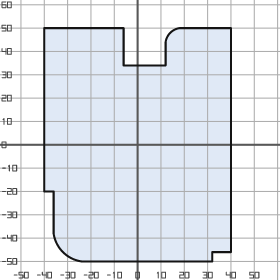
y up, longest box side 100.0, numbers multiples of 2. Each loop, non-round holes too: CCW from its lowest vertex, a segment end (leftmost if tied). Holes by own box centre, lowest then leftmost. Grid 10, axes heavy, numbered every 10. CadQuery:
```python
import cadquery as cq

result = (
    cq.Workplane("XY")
    .moveTo(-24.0, -50.0)
    .lineTo(32.0, -50.0)
    .lineTo(32.0, -46.0)
    .lineTo(40.0, -46.0)
    .lineTo(40.0, 50.0)
    .lineTo(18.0, 50.0)
    .threePointArc((14.0, 48.0), (12.0, 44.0))
    .lineTo(12.0, 34.0)
    .lineTo(-6.0, 34.0)
    .lineTo(-6.0, 50.0)
    .lineTo(-40.0, 50.0)
    .lineTo(-40.0, -20.0)
    .lineTo(-36.0, -20.0)
    .lineTo(-36.0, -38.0)
    .threePointArc((-32.0, -46.0), (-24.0, -50.0))
    .close()
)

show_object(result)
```